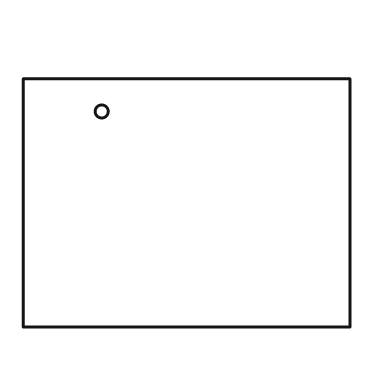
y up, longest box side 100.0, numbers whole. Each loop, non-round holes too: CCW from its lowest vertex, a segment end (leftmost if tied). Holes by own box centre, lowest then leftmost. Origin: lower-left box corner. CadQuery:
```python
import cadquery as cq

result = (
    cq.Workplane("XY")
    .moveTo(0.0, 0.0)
    .lineTo(100.0, 0.0)
    .lineTo(100.0, 76.0)
    .lineTo(0.0, 76.0)
    .close()
    .moveTo(24.0, 66.0)
    .circle(2.0)
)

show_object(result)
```